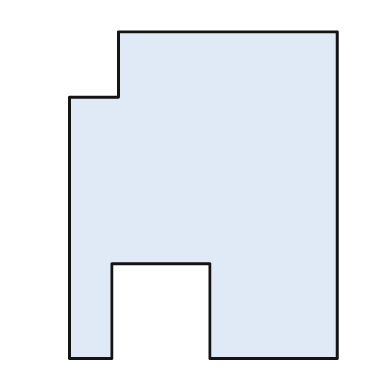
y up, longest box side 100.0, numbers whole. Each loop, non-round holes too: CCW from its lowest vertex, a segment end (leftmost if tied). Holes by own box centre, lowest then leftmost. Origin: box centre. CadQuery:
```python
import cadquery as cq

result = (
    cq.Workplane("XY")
    .moveTo(-41.0, -50.0)
    .lineTo(-28.0, -50.0)
    .lineTo(-28.0, -21.0)
    .lineTo(2.0, -21.0)
    .lineTo(2.0, -50.0)
    .lineTo(41.0, -50.0)
    .lineTo(41.0, 50.0)
    .lineTo(-26.0, 50.0)
    .lineTo(-26.0, 30.0)
    .lineTo(-41.0, 30.0)
    .close()
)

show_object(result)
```